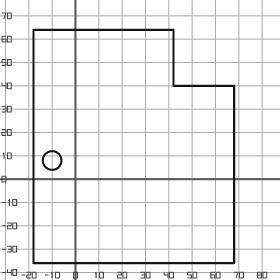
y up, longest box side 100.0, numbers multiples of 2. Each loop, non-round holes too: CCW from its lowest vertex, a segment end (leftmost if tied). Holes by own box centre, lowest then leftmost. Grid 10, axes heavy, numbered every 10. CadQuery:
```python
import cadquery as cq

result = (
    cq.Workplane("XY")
    .moveTo(-18.0, -36.0)
    .lineTo(68.0, -36.0)
    .lineTo(68.0, 40.0)
    .lineTo(42.0, 40.0)
    .lineTo(42.0, 64.0)
    .lineTo(-18.0, 64.0)
    .close()
    .moveTo(-10.0, 8.0)
    .circle(4.0)
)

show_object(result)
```